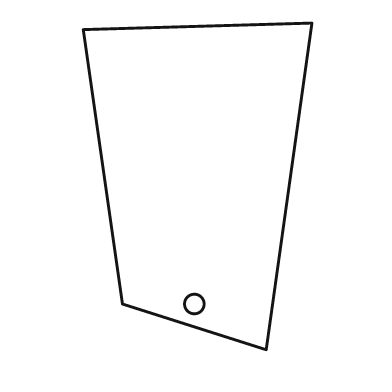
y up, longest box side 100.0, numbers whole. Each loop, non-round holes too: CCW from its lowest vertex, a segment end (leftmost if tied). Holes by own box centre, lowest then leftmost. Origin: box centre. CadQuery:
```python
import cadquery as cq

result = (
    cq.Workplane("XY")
    .moveTo(21.0, -50.0)
    .lineTo(35.0, 50.0)
    .lineTo(-35.0, 48.0)
    .lineTo(-23.0, -36.0)
    .close()
    .moveTo(-1.0, -36.0)
    .circle(3.0)
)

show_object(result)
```